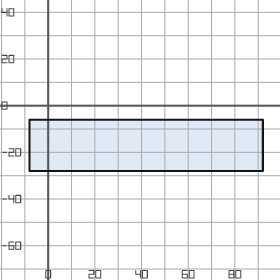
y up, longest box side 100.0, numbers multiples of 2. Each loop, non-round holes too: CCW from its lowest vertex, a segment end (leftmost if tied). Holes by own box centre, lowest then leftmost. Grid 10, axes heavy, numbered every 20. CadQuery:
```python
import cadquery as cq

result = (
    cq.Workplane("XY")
    .moveTo(-8.0, -28.0)
    .lineTo(92.0, -28.0)
    .lineTo(92.0, -6.0)
    .lineTo(-8.0, -6.0)
    .close()
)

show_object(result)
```